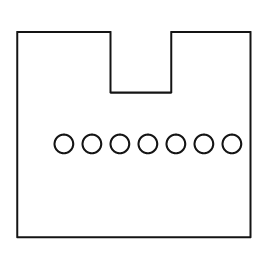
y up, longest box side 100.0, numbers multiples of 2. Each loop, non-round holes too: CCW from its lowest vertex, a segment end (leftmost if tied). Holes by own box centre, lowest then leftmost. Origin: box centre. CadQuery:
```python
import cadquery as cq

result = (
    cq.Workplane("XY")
    .moveTo(-50.0, -44.0)
    .lineTo(50.0, -44.0)
    .lineTo(50.0, 44.0)
    .lineTo(16.0, 44.0)
    .lineTo(16.0, 18.0)
    .lineTo(-10.0, 18.0)
    .lineTo(-10.0, 44.0)
    .lineTo(-50.0, 44.0)
    .close()
    .moveTo(-30.0, -4.0)
    .circle(4.0)
    .moveTo(-18.0, -4.0)
    .circle(4.0)
    .moveTo(-6.0, -4.0)
    .circle(4.0)
    .moveTo(6.0, -4.0)
    .circle(4.0)
    .moveTo(18.0, -4.0)
    .circle(4.0)
    .moveTo(30.0, -4.0)
    .circle(4.0)
    .moveTo(42.0, -4.0)
    .circle(4.0)
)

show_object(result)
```